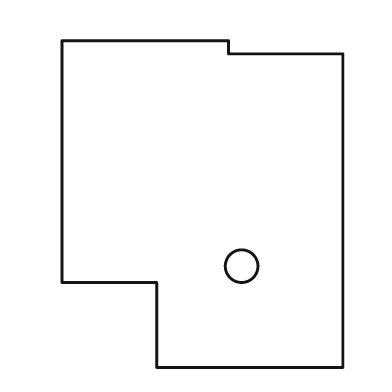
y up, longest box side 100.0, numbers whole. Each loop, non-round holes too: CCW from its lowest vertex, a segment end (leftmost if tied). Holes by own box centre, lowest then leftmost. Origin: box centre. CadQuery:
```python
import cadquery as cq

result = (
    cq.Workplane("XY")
    .moveTo(-14.0, -50.0)
    .lineTo(43.0, -50.0)
    .lineTo(43.0, 46.0)
    .lineTo(8.0, 46.0)
    .lineTo(8.0, 50.0)
    .lineTo(-43.0, 50.0)
    .lineTo(-43.0, -24.0)
    .lineTo(-14.0, -24.0)
    .close()
    .moveTo(12.0, -19.0)
    .circle(5.0)
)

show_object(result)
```